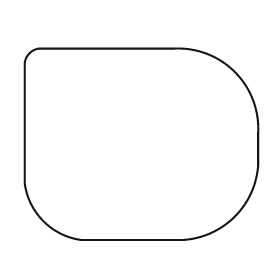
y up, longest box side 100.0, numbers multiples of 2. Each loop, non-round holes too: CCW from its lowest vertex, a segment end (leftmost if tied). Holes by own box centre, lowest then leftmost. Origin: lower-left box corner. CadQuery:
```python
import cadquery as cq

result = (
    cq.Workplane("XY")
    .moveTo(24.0, 0.0)
    .lineTo(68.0, 0.0)
    .threePointArc((90.0, 10.0), (100.0, 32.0))
    .lineTo(100.0, 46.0)
    .threePointArc((90.0, 72.0), (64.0, 82.0))
    .lineTo(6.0, 82.0)
    .threePointArc((2.0, 80.0), (0.0, 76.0))
    .lineTo(0.0, 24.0)
    .threePointArc((8.0, 8.0), (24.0, 0.0))
    .close()
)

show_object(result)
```